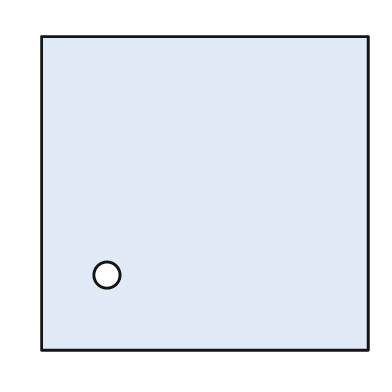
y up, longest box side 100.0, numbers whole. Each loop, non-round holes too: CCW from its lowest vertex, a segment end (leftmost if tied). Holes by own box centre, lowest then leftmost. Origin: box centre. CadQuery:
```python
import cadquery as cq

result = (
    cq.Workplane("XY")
    .moveTo(-50.0, -48.0)
    .lineTo(50.0, -48.0)
    .lineTo(50.0, 48.0)
    .lineTo(-50.0, 48.0)
    .close()
    .moveTo(-30.0, -25.0)
    .circle(4.0)
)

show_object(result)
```